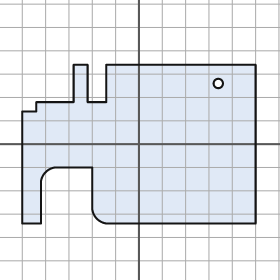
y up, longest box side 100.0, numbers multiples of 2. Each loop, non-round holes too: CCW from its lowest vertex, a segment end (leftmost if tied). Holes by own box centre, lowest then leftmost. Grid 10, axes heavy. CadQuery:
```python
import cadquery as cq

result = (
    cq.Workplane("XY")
    .moveTo(-50.0, -34.0)
    .lineTo(-42.0, -34.0)
    .lineTo(-42.0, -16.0)
    .threePointArc((-40.0, -12.0), (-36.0, -10.0))
    .lineTo(-20.0, -10.0)
    .lineTo(-20.0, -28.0)
    .threePointArc((-18.0, -32.0), (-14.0, -34.0))
    .lineTo(50.0, -34.0)
    .lineTo(50.0, 34.0)
    .lineTo(-14.0, 34.0)
    .lineTo(-14.0, 18.0)
    .lineTo(-22.0, 18.0)
    .lineTo(-22.0, 34.0)
    .lineTo(-28.0, 34.0)
    .lineTo(-28.0, 18.0)
    .lineTo(-44.0, 18.0)
    .lineTo(-44.0, 14.0)
    .lineTo(-50.0, 14.0)
    .close()
    .moveTo(34.0, 26.0)
    .circle(2.0)
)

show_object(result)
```